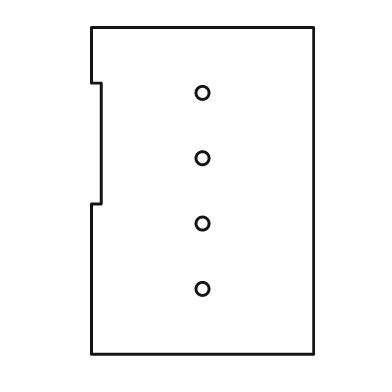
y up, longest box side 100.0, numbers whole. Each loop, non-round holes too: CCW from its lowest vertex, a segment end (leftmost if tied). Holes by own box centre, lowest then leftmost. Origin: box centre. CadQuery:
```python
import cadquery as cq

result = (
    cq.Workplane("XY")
    .moveTo(-34.0, -50.0)
    .lineTo(34.0, -50.0)
    .lineTo(34.0, 50.0)
    .lineTo(-34.0, 50.0)
    .lineTo(-34.0, 33.0)
    .lineTo(-31.0, 33.0)
    .lineTo(-31.0, -4.0)
    .lineTo(-34.0, -4.0)
    .close()
    .moveTo(0.0, -30.0)
    .circle(2.0)
    .moveTo(0.0, -10.0)
    .circle(2.0)
    .moveTo(0.0, 10.0)
    .circle(2.0)
    .moveTo(0.0, 30.0)
    .circle(2.0)
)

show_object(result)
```